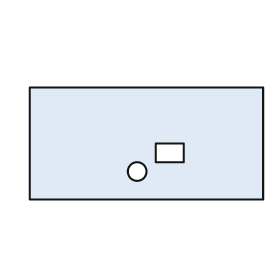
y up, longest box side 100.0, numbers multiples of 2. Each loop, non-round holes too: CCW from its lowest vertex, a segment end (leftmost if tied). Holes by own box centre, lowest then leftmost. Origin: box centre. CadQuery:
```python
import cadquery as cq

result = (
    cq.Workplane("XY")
    .moveTo(-50.0, -24.0)
    .lineTo(50.0, -24.0)
    .lineTo(50.0, 24.0)
    .lineTo(-50.0, 24.0)
    .close()
    .moveTo(-4.0, -12.0)
    .circle(4.0)
    .moveTo(4.0, -8.0)
    .lineTo(16.0, -8.0)
    .lineTo(16.0, 0.0)
    .lineTo(4.0, 0.0)
    .close()
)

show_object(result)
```